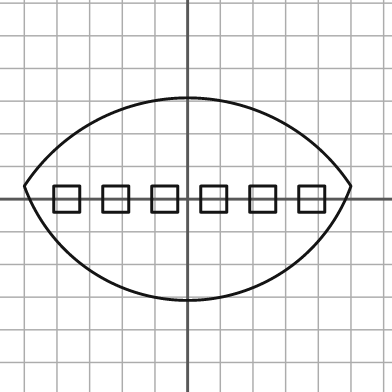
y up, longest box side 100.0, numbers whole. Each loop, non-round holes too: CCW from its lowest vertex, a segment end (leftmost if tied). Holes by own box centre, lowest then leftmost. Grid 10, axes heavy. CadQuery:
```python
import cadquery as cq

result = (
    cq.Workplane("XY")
    .moveTo(-50.0, 4.0)
    .threePointArc((0.0, -31.0), (50.0, 4.0))
    .threePointArc((0.0, 31.0), (-50.0, 4.0))
    .close()
    .moveTo(-41.0, -4.0)
    .lineTo(-33.0, -4.0)
    .lineTo(-33.0, 4.0)
    .lineTo(-41.0, 4.0)
    .close()
    .moveTo(-26.0, -4.0)
    .lineTo(-18.0, -4.0)
    .lineTo(-18.0, 4.0)
    .lineTo(-26.0, 4.0)
    .close()
    .moveTo(-11.0, -4.0)
    .lineTo(-3.0, -4.0)
    .lineTo(-3.0, 4.0)
    .lineTo(-11.0, 4.0)
    .close()
    .moveTo(4.0, -4.0)
    .lineTo(12.0, -4.0)
    .lineTo(12.0, 4.0)
    .lineTo(4.0, 4.0)
    .close()
    .moveTo(19.0, -4.0)
    .lineTo(27.0, -4.0)
    .lineTo(27.0, 4.0)
    .lineTo(19.0, 4.0)
    .close()
    .moveTo(34.0, -4.0)
    .lineTo(42.0, -4.0)
    .lineTo(42.0, 4.0)
    .lineTo(34.0, 4.0)
    .close()
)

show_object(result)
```